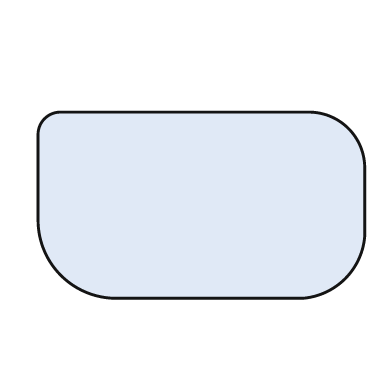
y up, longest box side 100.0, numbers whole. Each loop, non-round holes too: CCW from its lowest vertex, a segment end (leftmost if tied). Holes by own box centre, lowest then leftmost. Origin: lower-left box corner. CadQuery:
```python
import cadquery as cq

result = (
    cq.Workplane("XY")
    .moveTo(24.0, 0.0)
    .lineTo(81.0, 0.0)
    .threePointArc((94.0, 6.0), (100.0, 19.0))
    .lineTo(100.0, 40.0)
    .threePointArc((95.0, 52.0), (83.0, 57.0))
    .lineTo(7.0, 57.0)
    .threePointArc((2.0, 55.0), (0.0, 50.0))
    .lineTo(0.0, 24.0)
    .threePointArc((7.0, 7.0), (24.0, 0.0))
    .close()
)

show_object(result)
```